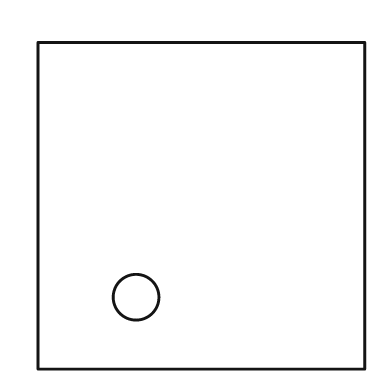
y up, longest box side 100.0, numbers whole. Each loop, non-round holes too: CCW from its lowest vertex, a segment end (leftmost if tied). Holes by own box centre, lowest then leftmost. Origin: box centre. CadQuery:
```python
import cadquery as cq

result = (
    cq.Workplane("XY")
    .moveTo(-50.0, -50.0)
    .lineTo(50.0, -50.0)
    .lineTo(50.0, 50.0)
    .lineTo(-50.0, 50.0)
    .close()
    .moveTo(-20.0, -28.0)
    .circle(7.0)
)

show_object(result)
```